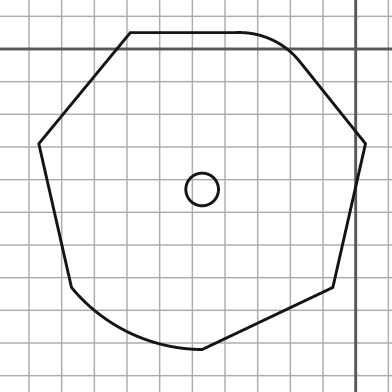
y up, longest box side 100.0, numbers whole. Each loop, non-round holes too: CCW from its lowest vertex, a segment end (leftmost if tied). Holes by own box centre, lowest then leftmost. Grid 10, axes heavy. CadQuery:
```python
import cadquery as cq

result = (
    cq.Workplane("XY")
    .moveTo(-47.0, -92.0)
    .lineTo(-7.0, -73.0)
    .lineTo(3.0, -29.0)
    .lineTo(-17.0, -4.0)
    .threePointArc((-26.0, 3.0), (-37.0, 5.0))
    .lineTo(-69.0, 5.0)
    .lineTo(-97.0, -29.0)
    .lineTo(-87.0, -73.0)
    .threePointArc((-69.0, -87.0), (-47.0, -92.0))
    .close()
    .moveTo(-47.0, -43.0)
    .circle(5.0)
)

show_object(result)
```